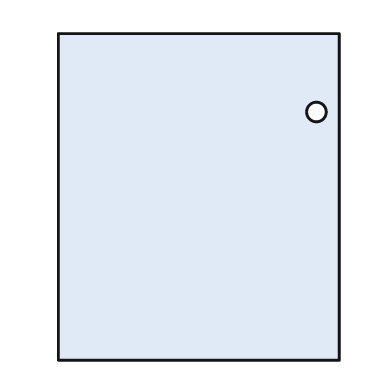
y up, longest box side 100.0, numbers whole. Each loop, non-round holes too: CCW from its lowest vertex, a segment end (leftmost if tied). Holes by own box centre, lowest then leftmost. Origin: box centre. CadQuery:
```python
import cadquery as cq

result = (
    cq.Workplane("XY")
    .moveTo(-43.0, -50.0)
    .lineTo(43.0, -50.0)
    .lineTo(43.0, 50.0)
    .lineTo(-43.0, 50.0)
    .close()
    .moveTo(36.0, 26.0)
    .circle(3.0)
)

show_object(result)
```